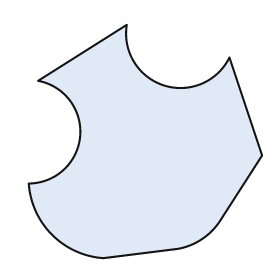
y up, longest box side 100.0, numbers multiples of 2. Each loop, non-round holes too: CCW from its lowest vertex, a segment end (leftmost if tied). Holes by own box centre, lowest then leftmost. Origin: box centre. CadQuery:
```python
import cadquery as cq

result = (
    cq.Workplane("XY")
    .moveTo(-18.0, -50.0)
    .lineTo(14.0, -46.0)
    .threePointArc((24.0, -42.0), (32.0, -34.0))
    .lineTo(50.0, -6.0)
    .lineTo(36.0, 36.0)
    .threePointArc((8.0, 24.0), (-8.0, 50.0))
    .lineTo(-46.0, 26.0)
    .threePointArc((-28.0, 2.0), (-50.0, -18.0))
    .threePointArc((-40.0, -40.0), (-18.0, -50.0))
    .close()
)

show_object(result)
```